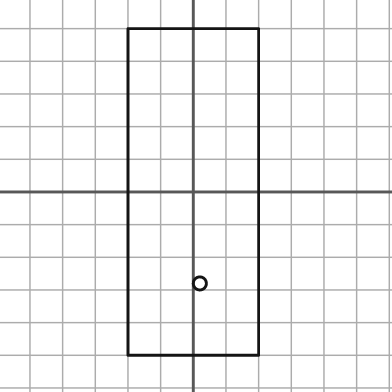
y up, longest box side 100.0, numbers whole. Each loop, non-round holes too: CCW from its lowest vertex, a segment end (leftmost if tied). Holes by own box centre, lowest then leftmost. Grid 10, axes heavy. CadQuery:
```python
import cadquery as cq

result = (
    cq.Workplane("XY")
    .moveTo(-20.0, -50.0)
    .lineTo(20.0, -50.0)
    .lineTo(20.0, 50.0)
    .lineTo(-20.0, 50.0)
    .close()
    .moveTo(2.0, -28.0)
    .circle(2.0)
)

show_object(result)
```